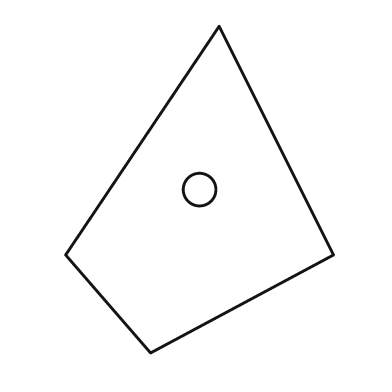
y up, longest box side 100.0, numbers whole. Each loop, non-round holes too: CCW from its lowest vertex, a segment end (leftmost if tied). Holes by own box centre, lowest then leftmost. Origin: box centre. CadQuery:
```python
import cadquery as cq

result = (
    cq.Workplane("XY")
    .moveTo(-15.0, -50.0)
    .lineTo(41.0, -20.0)
    .lineTo(6.0, 50.0)
    .lineTo(-41.0, -20.0)
    .close()
    .moveTo(0.0, 0.0)
    .circle(5.0)
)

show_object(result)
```